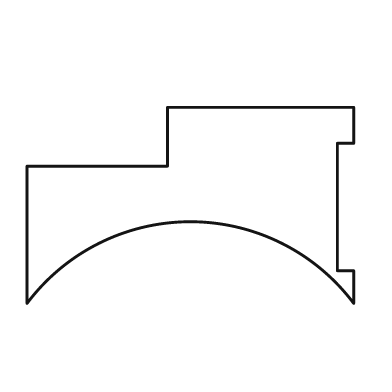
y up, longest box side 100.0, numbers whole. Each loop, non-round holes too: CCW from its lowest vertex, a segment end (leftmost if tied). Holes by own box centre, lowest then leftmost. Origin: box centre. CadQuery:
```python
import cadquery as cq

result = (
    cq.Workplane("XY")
    .moveTo(-50.0, -30.0)
    .threePointArc((0.0, -5.0), (50.0, -30.0))
    .lineTo(50.0, -20.0)
    .lineTo(45.0, -20.0)
    .lineTo(45.0, 19.0)
    .lineTo(50.0, 19.0)
    .lineTo(50.0, 30.0)
    .lineTo(-7.0, 30.0)
    .lineTo(-7.0, 12.0)
    .lineTo(-50.0, 12.0)
    .close()
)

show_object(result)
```